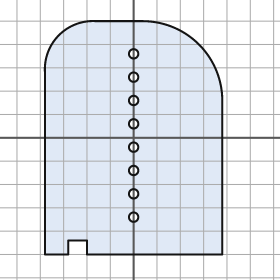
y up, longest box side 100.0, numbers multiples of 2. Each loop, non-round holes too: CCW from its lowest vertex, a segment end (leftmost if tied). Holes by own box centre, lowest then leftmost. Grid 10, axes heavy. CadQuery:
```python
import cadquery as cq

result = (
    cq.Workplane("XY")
    .moveTo(-38.0, -50.0)
    .lineTo(-28.0, -50.0)
    .lineTo(-28.0, -44.0)
    .lineTo(-20.0, -44.0)
    .lineTo(-20.0, -50.0)
    .lineTo(38.0, -50.0)
    .lineTo(38.0, 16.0)
    .threePointArc((28.0, 40.0), (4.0, 50.0))
    .lineTo(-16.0, 50.0)
    .threePointArc((-32.0, 44.0), (-38.0, 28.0))
    .close()
    .moveTo(0.0, -34.0)
    .circle(2.0)
    .moveTo(0.0, -24.0)
    .circle(2.0)
    .moveTo(0.0, -14.0)
    .circle(2.0)
    .moveTo(0.0, -4.0)
    .circle(2.0)
    .moveTo(0.0, 6.0)
    .circle(2.0)
    .moveTo(0.0, 16.0)
    .circle(2.0)
    .moveTo(0.0, 26.0)
    .circle(2.0)
    .moveTo(0.0, 36.0)
    .circle(2.0)
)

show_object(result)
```